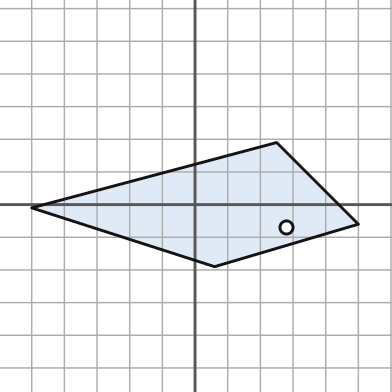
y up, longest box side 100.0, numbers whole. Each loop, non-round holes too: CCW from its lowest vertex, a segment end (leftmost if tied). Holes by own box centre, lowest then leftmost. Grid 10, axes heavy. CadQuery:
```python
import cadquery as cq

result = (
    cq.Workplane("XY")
    .moveTo(6.0, -19.0)
    .lineTo(50.0, -6.0)
    .lineTo(25.0, 19.0)
    .lineTo(-50.0, -1.0)
    .close()
    .moveTo(28.0, -7.0)
    .circle(2.0)
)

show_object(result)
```